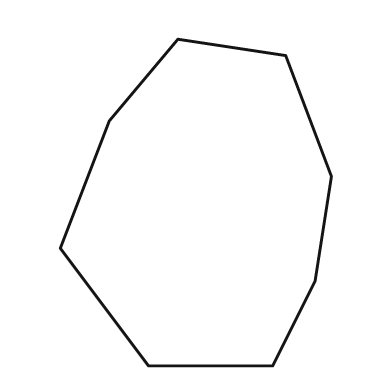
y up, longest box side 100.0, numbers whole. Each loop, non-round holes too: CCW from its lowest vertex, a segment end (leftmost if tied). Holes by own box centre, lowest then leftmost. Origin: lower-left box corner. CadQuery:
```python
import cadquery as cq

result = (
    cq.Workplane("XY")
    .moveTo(27.0, 0.0)
    .lineTo(65.0, 0.0)
    .lineTo(78.0, 26.0)
    .lineTo(83.0, 58.0)
    .lineTo(69.0, 95.0)
    .lineTo(36.0, 100.0)
    .lineTo(15.0, 75.0)
    .lineTo(0.0, 36.0)
    .close()
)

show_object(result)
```